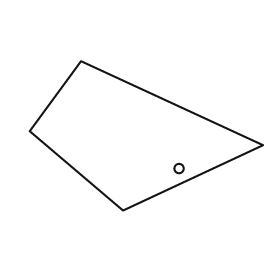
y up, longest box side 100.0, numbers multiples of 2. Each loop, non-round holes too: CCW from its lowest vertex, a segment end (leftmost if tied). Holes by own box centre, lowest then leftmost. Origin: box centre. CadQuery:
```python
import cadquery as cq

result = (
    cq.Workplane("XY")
    .moveTo(-10.0, -32.0)
    .lineTo(50.0, -4.0)
    .lineTo(-28.0, 32.0)
    .lineTo(-50.0, 2.0)
    .close()
    .moveTo(14.0, -14.0)
    .circle(2.0)
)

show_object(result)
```